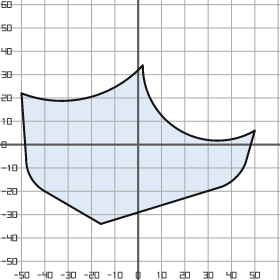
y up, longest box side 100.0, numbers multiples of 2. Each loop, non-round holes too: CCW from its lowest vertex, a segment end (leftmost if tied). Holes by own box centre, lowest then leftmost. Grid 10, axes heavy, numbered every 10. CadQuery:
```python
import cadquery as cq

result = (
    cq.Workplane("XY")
    .moveTo(-16.0, -34.0)
    .lineTo(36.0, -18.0)
    .threePointArc((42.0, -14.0), (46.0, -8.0))
    .lineTo(50.0, 6.0)
    .threePointArc((18.0, 6.0), (2.0, 34.0))
    .threePointArc((-22.0, 20.0), (-50.0, 22.0))
    .lineTo(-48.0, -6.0)
    .threePointArc((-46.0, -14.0), (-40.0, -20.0))
    .close()
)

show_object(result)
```